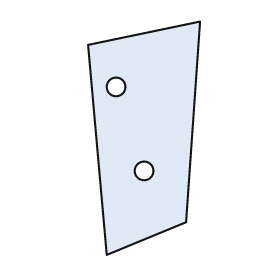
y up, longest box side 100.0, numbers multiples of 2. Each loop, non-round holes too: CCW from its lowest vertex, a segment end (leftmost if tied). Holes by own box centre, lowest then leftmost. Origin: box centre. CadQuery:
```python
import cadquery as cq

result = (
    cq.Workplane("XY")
    .moveTo(-16.0, -50.0)
    .lineTo(18.0, -36.0)
    .lineTo(24.0, 50.0)
    .lineTo(-24.0, 40.0)
    .close()
    .moveTo(0.0, -14.0)
    .circle(4.0)
    .moveTo(-12.0, 22.0)
    .circle(4.0)
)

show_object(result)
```